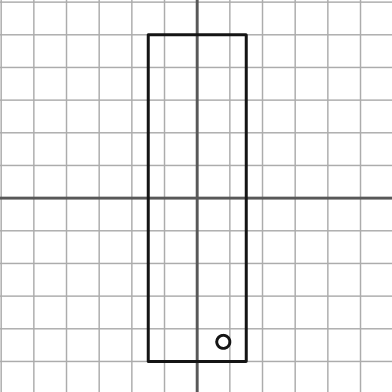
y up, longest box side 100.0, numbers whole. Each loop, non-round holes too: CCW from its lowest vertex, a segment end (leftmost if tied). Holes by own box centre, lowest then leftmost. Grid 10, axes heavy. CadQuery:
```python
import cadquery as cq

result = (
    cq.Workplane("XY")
    .moveTo(-15.0, -50.0)
    .lineTo(15.0, -50.0)
    .lineTo(15.0, 50.0)
    .lineTo(-15.0, 50.0)
    .close()
    .moveTo(8.0, -44.0)
    .circle(2.0)
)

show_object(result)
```